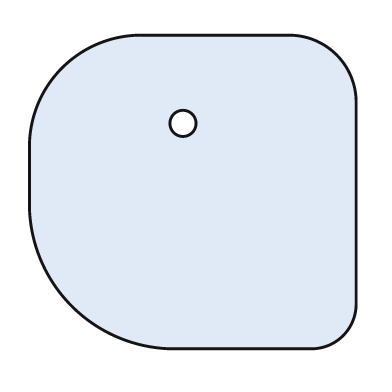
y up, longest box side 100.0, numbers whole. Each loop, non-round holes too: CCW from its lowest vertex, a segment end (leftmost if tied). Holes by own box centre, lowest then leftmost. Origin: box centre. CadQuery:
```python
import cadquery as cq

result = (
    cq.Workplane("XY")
    .moveTo(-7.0, -48.0)
    .lineTo(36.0, -48.0)
    .threePointArc((46.0, -44.0), (50.0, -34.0))
    .lineTo(50.0, 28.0)
    .threePointArc((44.0, 42.0), (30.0, 48.0))
    .lineTo(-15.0, 48.0)
    .threePointArc((-40.0, 38.0), (-50.0, 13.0))
    .lineTo(-50.0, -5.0)
    .threePointArc((-37.0, -35.0), (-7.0, -48.0))
    .close()
    .moveTo(-3.0, 21.0)
    .circle(4.0)
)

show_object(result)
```